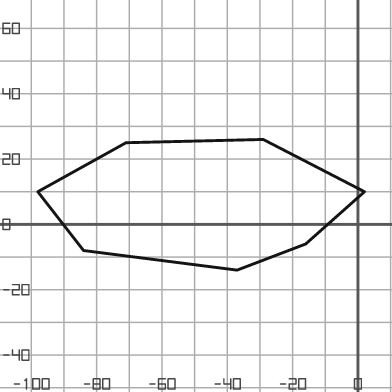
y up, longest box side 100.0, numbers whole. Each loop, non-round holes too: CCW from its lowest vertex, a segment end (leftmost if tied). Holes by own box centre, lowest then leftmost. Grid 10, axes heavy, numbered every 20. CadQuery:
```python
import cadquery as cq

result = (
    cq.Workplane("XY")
    .moveTo(-37.0, -14.0)
    .lineTo(-16.0, -6.0)
    .lineTo(2.0, 10.0)
    .lineTo(-29.0, 26.0)
    .lineTo(-71.0, 25.0)
    .lineTo(-98.0, 10.0)
    .lineTo(-84.0, -8.0)
    .close()
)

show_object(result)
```